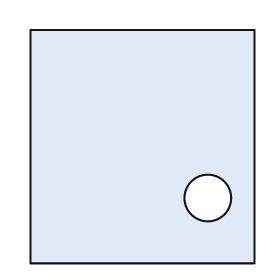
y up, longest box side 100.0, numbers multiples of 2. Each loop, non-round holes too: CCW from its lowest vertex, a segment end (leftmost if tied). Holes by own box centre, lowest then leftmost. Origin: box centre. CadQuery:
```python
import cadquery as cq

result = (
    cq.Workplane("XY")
    .moveTo(-48.0, -50.0)
    .lineTo(48.0, -50.0)
    .lineTo(48.0, 50.0)
    .lineTo(-48.0, 50.0)
    .close()
    .moveTo(28.0, -22.0)
    .circle(10.0)
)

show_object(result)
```